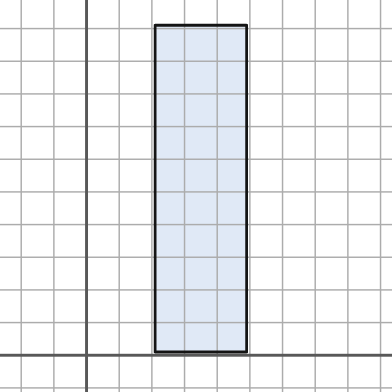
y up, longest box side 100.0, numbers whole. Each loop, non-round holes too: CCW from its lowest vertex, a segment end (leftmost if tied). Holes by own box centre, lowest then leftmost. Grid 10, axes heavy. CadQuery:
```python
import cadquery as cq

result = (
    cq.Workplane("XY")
    .moveTo(21.0, 1.0)
    .lineTo(49.0, 1.0)
    .lineTo(49.0, 101.0)
    .lineTo(21.0, 101.0)
    .close()
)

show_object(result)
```